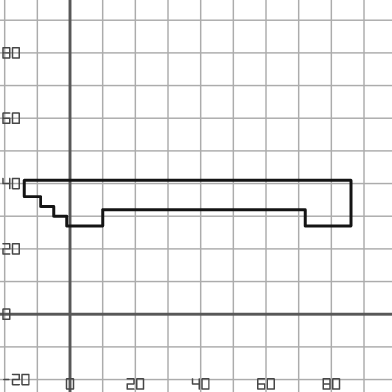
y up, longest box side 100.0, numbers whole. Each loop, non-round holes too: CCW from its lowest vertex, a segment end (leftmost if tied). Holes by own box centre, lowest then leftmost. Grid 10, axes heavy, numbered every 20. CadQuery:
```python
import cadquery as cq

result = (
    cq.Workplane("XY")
    .moveTo(-1.0, 27.0)
    .lineTo(10.0, 27.0)
    .lineTo(10.0, 32.0)
    .lineTo(72.0, 32.0)
    .lineTo(72.0, 27.0)
    .lineTo(86.0, 27.0)
    .lineTo(86.0, 41.0)
    .lineTo(-14.0, 41.0)
    .lineTo(-14.0, 36.0)
    .lineTo(-9.0, 36.0)
    .lineTo(-9.0, 33.0)
    .lineTo(-5.0, 33.0)
    .lineTo(-5.0, 30.0)
    .lineTo(-1.0, 30.0)
    .close()
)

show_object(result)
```